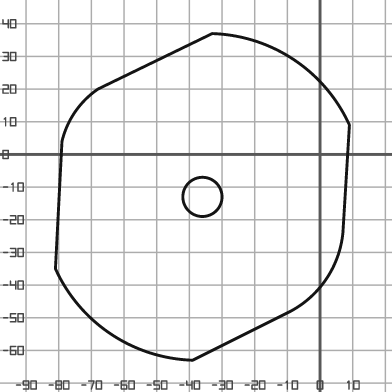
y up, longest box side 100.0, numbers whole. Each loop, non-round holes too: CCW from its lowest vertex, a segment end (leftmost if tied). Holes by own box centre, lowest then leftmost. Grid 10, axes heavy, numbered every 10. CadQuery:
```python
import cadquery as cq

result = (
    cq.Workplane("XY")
    .moveTo(-39.0, -63.0)
    .lineTo(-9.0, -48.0)
    .threePointArc((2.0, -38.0), (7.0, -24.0))
    .lineTo(9.0, 9.0)
    .threePointArc((-8.0, 29.0), (-33.0, 37.0))
    .lineTo(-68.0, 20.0)
    .threePointArc((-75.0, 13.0), (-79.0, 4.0))
    .lineTo(-81.0, -35.0)
    .threePointArc((-64.0, -55.0), (-39.0, -63.0))
    .close()
    .moveTo(-36.0, -13.0)
    .circle(6.0)
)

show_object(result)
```